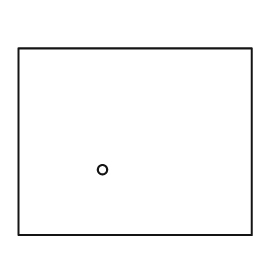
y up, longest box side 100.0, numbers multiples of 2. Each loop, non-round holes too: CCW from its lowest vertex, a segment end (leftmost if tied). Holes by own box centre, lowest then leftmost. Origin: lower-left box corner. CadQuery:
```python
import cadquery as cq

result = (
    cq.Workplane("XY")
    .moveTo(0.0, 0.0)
    .lineTo(100.0, 0.0)
    .lineTo(100.0, 80.0)
    .lineTo(0.0, 80.0)
    .close()
    .moveTo(36.0, 28.0)
    .circle(2.0)
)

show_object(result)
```